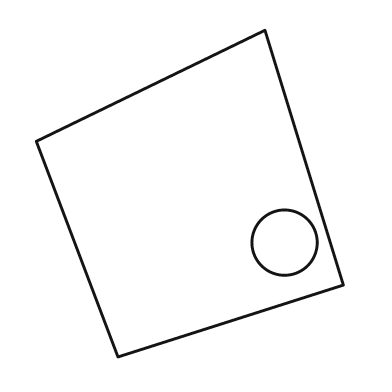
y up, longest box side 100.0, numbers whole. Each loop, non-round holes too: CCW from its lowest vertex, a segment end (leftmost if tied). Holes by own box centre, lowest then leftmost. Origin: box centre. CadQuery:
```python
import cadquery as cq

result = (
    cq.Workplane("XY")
    .moveTo(-22.0, -50.0)
    .lineTo(47.0, -28.0)
    .lineTo(23.0, 50.0)
    .lineTo(-47.0, 16.0)
    .close()
    .moveTo(29.0, -15.0)
    .circle(10.0)
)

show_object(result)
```